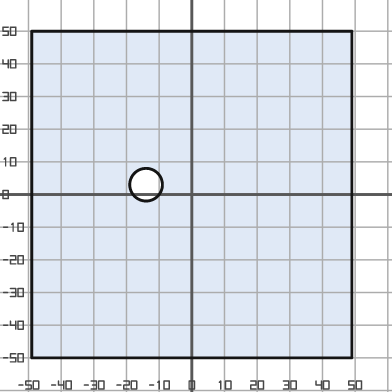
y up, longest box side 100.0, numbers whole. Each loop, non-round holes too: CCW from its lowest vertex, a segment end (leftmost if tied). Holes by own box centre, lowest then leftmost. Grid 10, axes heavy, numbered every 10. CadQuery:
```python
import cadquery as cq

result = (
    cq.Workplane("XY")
    .moveTo(-49.0, -50.0)
    .lineTo(49.0, -50.0)
    .lineTo(49.0, 50.0)
    .lineTo(-49.0, 50.0)
    .close()
    .moveTo(-14.0, 3.0)
    .circle(5.0)
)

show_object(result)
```